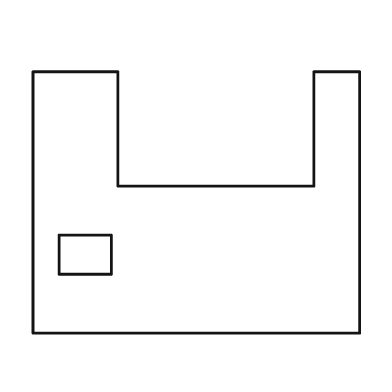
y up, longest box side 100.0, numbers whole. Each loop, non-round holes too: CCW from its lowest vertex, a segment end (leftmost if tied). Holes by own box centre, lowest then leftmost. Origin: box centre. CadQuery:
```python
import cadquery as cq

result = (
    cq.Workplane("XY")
    .moveTo(-50.0, -40.0)
    .lineTo(50.0, -40.0)
    .lineTo(50.0, 40.0)
    .lineTo(36.0, 40.0)
    .lineTo(36.0, 5.0)
    .lineTo(-24.0, 5.0)
    .lineTo(-24.0, 40.0)
    .lineTo(-50.0, 40.0)
    .close()
    .moveTo(-42.0, -22.0)
    .lineTo(-26.0, -22.0)
    .lineTo(-26.0, -10.0)
    .lineTo(-42.0, -10.0)
    .close()
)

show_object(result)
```